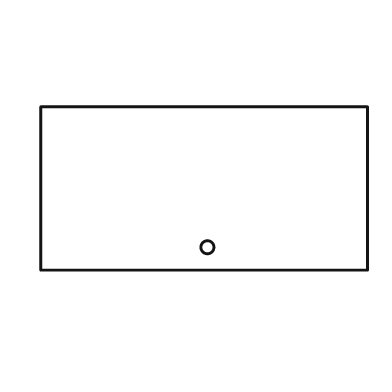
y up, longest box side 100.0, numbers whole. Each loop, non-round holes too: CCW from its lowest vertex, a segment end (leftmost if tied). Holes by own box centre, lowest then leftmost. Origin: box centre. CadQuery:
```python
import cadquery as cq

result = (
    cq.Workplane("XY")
    .moveTo(-50.0, -25.0)
    .lineTo(50.0, -25.0)
    .lineTo(50.0, 25.0)
    .lineTo(-50.0, 25.0)
    .close()
    .moveTo(1.0, -18.0)
    .circle(2.0)
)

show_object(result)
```